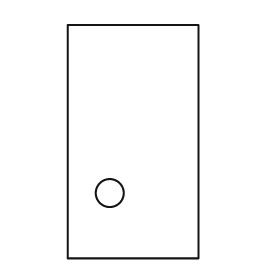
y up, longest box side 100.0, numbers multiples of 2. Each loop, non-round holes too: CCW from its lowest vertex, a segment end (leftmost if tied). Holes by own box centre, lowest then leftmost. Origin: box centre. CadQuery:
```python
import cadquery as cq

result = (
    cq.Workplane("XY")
    .moveTo(-28.0, -50.0)
    .lineTo(28.0, -50.0)
    .lineTo(28.0, 50.0)
    .lineTo(-28.0, 50.0)
    .close()
    .moveTo(-10.0, -22.0)
    .circle(6.0)
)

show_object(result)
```